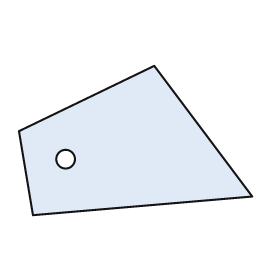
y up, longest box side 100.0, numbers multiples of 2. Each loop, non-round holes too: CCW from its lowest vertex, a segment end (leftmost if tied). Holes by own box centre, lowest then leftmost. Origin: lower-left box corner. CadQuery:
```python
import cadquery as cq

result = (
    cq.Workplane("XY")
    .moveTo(6.0, 0.0)
    .lineTo(100.0, 8.0)
    .lineTo(58.0, 64.0)
    .lineTo(0.0, 36.0)
    .close()
    .moveTo(20.0, 24.0)
    .circle(4.0)
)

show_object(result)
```